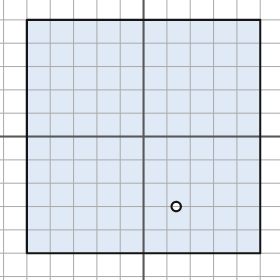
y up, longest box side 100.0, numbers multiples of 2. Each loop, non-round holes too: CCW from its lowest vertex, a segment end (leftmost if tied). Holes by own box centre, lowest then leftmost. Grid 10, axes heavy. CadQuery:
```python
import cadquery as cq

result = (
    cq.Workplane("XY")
    .moveTo(-50.0, -50.0)
    .lineTo(50.0, -50.0)
    .lineTo(50.0, 50.0)
    .lineTo(-50.0, 50.0)
    .close()
    .moveTo(14.0, -30.0)
    .circle(2.0)
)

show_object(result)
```